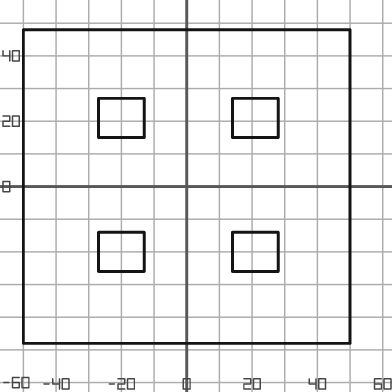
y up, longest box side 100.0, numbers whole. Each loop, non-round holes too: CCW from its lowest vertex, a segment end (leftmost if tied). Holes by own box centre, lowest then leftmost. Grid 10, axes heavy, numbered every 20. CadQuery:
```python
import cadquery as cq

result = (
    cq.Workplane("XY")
    .moveTo(-50.0, -48.0)
    .lineTo(50.0, -48.0)
    .lineTo(50.0, 48.0)
    .lineTo(-50.0, 48.0)
    .close()
    .moveTo(-27.0, -26.0)
    .lineTo(-13.0, -26.0)
    .lineTo(-13.0, -14.0)
    .lineTo(-27.0, -14.0)
    .close()
    .moveTo(14.0, -26.0)
    .lineTo(28.0, -26.0)
    .lineTo(28.0, -14.0)
    .lineTo(14.0, -14.0)
    .close()
    .moveTo(-27.0, 15.0)
    .lineTo(-13.0, 15.0)
    .lineTo(-13.0, 27.0)
    .lineTo(-27.0, 27.0)
    .close()
    .moveTo(14.0, 15.0)
    .lineTo(28.0, 15.0)
    .lineTo(28.0, 27.0)
    .lineTo(14.0, 27.0)
    .close()
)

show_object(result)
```